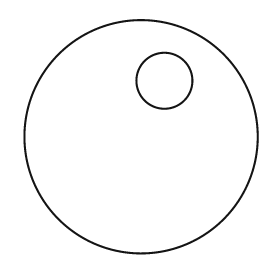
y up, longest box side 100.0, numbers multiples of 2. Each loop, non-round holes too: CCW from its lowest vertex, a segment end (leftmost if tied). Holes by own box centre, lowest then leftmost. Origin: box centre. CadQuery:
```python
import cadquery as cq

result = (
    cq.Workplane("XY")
    .moveTo(0.0, 0.0)
    .circle(50.0)
    .moveTo(10.0, 24.0)
    .circle(12.0)
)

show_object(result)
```